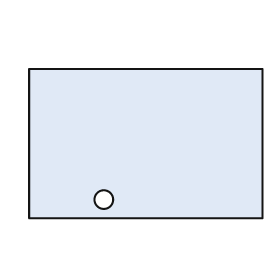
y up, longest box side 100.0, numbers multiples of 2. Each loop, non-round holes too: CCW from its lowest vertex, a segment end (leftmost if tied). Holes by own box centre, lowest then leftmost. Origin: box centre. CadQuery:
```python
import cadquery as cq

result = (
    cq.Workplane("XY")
    .moveTo(-50.0, -32.0)
    .lineTo(50.0, -32.0)
    .lineTo(50.0, 32.0)
    .lineTo(-50.0, 32.0)
    .close()
    .moveTo(-18.0, -24.0)
    .circle(4.0)
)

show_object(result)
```